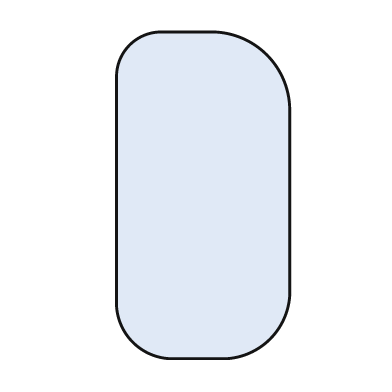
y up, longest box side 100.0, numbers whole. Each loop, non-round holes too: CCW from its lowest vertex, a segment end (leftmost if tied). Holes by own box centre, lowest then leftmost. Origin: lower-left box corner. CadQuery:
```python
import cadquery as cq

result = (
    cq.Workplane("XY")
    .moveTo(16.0, 0.0)
    .lineTo(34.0, 0.0)
    .threePointArc((47.0, 6.0), (53.0, 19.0))
    .lineTo(53.0, 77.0)
    .threePointArc((46.0, 93.0), (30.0, 100.0))
    .lineTo(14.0, 100.0)
    .threePointArc((4.0, 96.0), (0.0, 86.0))
    .lineTo(0.0, 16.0)
    .threePointArc((5.0, 5.0), (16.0, 0.0))
    .close()
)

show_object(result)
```